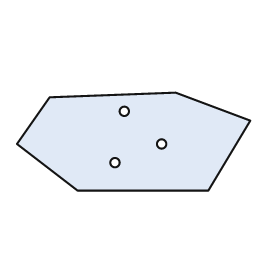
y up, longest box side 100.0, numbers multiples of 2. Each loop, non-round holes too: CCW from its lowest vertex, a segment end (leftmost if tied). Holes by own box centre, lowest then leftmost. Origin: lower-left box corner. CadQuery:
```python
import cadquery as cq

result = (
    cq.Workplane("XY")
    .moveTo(26.0, 0.0)
    .lineTo(82.0, 0.0)
    .lineTo(100.0, 30.0)
    .lineTo(68.0, 42.0)
    .lineTo(14.0, 40.0)
    .lineTo(0.0, 20.0)
    .close()
    .moveTo(42.0, 12.0)
    .circle(2.0)
    .moveTo(62.0, 20.0)
    .circle(2.0)
    .moveTo(46.0, 34.0)
    .circle(2.0)
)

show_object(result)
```